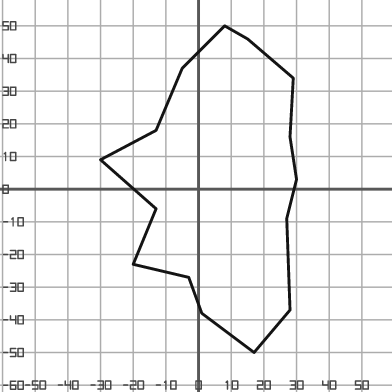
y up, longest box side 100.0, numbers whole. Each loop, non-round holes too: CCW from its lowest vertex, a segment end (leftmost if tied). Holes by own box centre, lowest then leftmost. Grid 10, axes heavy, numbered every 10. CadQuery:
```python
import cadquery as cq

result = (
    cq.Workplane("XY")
    .moveTo(17.0, -50.0)
    .lineTo(28.0, -37.0)
    .lineTo(27.0, -9.0)
    .lineTo(30.0, 3.0)
    .lineTo(28.0, 16.0)
    .lineTo(29.0, 34.0)
    .lineTo(15.0, 46.0)
    .lineTo(8.0, 50.0)
    .lineTo(-5.0, 37.0)
    .lineTo(-13.0, 18.0)
    .lineTo(-30.0, 9.0)
    .lineTo(-13.0, -6.0)
    .lineTo(-20.0, -23.0)
    .lineTo(-3.0, -27.0)
    .lineTo(1.0, -38.0)
    .close()
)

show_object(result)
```